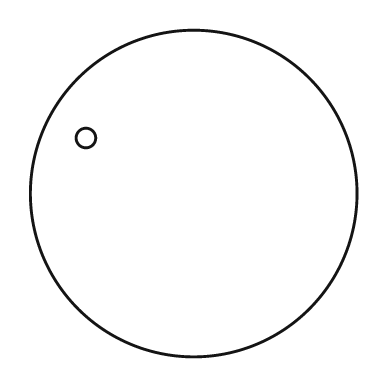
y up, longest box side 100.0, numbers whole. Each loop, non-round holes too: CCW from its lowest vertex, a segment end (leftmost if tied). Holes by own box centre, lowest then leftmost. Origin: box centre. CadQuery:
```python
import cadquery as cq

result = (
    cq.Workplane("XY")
    .moveTo(0.0, 0.0)
    .circle(50.0)
    .moveTo(-33.0, 17.0)
    .circle(3.0)
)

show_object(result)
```